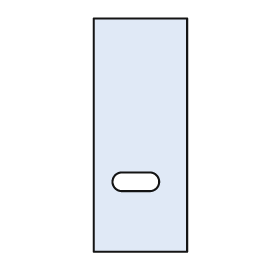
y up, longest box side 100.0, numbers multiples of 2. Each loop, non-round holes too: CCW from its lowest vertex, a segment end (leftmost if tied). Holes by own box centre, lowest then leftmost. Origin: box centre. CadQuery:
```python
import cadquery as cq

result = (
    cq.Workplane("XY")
    .moveTo(-20.0, -50.0)
    .lineTo(20.0, -50.0)
    .lineTo(20.0, 50.0)
    .lineTo(-20.0, 50.0)
    .close()
    .moveTo(-8.0, -24.0)
    .lineTo(4.0, -24.0)
    .threePointArc((8.0, -20.0), (4.0, -16.0))
    .lineTo(-8.0, -16.0)
    .threePointArc((-12.0, -20.0), (-8.0, -24.0))
    .close()
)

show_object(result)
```